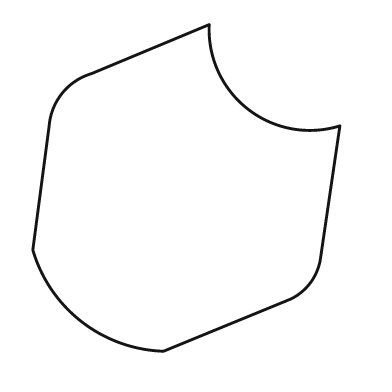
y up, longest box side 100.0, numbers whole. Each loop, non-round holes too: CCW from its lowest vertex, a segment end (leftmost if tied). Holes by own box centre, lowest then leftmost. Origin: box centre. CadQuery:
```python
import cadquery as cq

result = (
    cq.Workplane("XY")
    .moveTo(-7.0, -50.0)
    .lineTo(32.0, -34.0)
    .threePointArc((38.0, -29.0), (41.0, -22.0))
    .lineTo(47.0, 19.0)
    .threePointArc((19.0, 24.0), (7.0, 50.0))
    .lineTo(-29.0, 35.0)
    .threePointArc((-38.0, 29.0), (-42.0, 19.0))
    .lineTo(-47.0, -19.0)
    .threePointArc((-32.0, -41.0), (-7.0, -50.0))
    .close()
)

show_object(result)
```